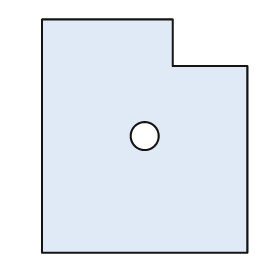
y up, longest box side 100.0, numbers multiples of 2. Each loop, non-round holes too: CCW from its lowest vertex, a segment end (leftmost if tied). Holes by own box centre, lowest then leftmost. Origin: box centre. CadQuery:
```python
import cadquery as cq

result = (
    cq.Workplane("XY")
    .moveTo(-44.0, -50.0)
    .lineTo(44.0, -50.0)
    .lineTo(44.0, 30.0)
    .lineTo(12.0, 30.0)
    .lineTo(12.0, 50.0)
    .lineTo(-44.0, 50.0)
    .close()
    .moveTo(0.0, 0.0)
    .circle(6.0)
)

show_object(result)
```